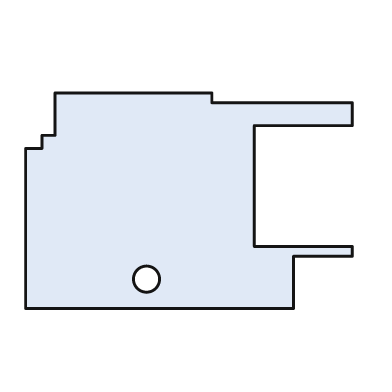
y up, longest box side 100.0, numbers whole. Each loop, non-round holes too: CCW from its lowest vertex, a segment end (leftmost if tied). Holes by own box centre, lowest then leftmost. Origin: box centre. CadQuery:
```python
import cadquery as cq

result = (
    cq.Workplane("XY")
    .moveTo(-50.0, -33.0)
    .lineTo(32.0, -33.0)
    .lineTo(32.0, -17.0)
    .lineTo(50.0, -17.0)
    .lineTo(50.0, -14.0)
    .lineTo(20.0, -14.0)
    .lineTo(20.0, 23.0)
    .lineTo(50.0, 23.0)
    .lineTo(50.0, 30.0)
    .lineTo(7.0, 30.0)
    .lineTo(7.0, 33.0)
    .lineTo(-41.0, 33.0)
    .lineTo(-41.0, 20.0)
    .lineTo(-45.0, 20.0)
    .lineTo(-45.0, 16.0)
    .lineTo(-50.0, 16.0)
    .close()
    .moveTo(-13.0, -24.0)
    .circle(4.0)
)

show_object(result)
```